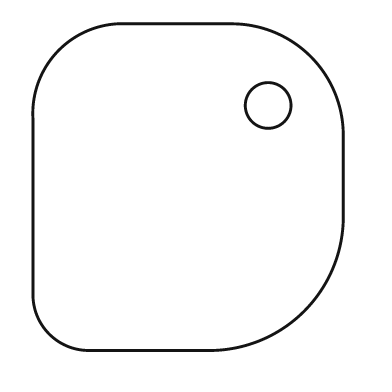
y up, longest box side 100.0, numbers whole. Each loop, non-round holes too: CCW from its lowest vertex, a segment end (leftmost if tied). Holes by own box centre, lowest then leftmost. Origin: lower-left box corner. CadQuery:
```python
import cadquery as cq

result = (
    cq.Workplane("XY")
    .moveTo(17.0, 0.0)
    .lineTo(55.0, 0.0)
    .threePointArc((83.0, 12.0), (95.0, 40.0))
    .lineTo(95.0, 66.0)
    .threePointArc((85.0, 90.0), (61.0, 100.0))
    .lineTo(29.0, 100.0)
    .threePointArc((8.0, 92.0), (0.0, 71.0))
    .lineTo(0.0, 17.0)
    .threePointArc((5.0, 5.0), (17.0, 0.0))
    .close()
    .moveTo(72.0, 75.0)
    .circle(7.0)
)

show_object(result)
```